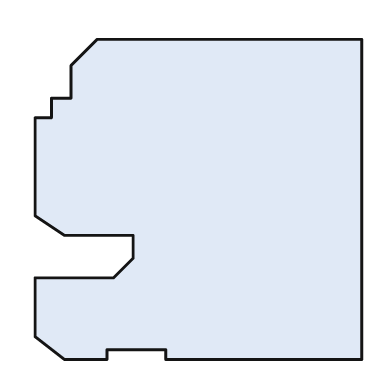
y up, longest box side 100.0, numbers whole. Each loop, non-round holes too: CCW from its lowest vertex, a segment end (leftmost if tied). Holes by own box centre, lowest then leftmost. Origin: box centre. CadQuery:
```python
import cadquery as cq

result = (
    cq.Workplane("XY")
    .moveTo(-41.0, -49.0)
    .lineTo(-28.0, -49.0)
    .lineTo(-28.0, -46.0)
    .lineTo(-10.0, -46.0)
    .lineTo(-10.0, -49.0)
    .lineTo(50.0, -49.0)
    .lineTo(50.0, 49.0)
    .lineTo(-31.0, 49.0)
    .lineTo(-39.0, 41.0)
    .lineTo(-39.0, 31.0)
    .lineTo(-45.0, 31.0)
    .lineTo(-45.0, 25.0)
    .lineTo(-50.0, 25.0)
    .lineTo(-50.0, -5.0)
    .lineTo(-41.0, -11.0)
    .lineTo(-20.0, -11.0)
    .lineTo(-20.0, -18.0)
    .lineTo(-26.0, -24.0)
    .lineTo(-50.0, -24.0)
    .lineTo(-50.0, -42.0)
    .close()
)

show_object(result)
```